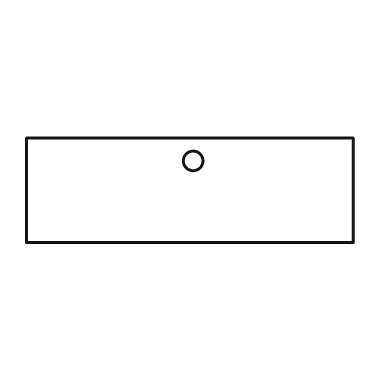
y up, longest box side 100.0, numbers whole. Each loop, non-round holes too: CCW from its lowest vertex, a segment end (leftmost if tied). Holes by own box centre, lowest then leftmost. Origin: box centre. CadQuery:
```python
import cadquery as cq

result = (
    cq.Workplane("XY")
    .moveTo(-50.0, -16.0)
    .lineTo(50.0, -16.0)
    .lineTo(50.0, 16.0)
    .lineTo(-50.0, 16.0)
    .close()
    .moveTo(1.0, 9.0)
    .circle(3.0)
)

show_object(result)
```